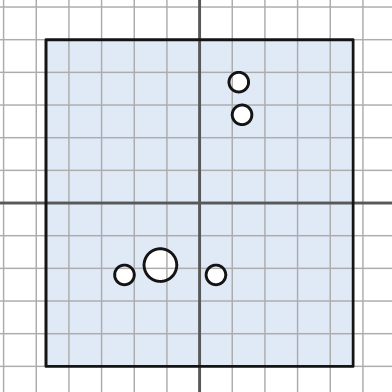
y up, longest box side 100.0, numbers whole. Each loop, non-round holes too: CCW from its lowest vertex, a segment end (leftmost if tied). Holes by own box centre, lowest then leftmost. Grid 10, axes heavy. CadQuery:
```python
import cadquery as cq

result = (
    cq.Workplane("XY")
    .moveTo(-47.0, -50.0)
    .lineTo(47.0, -50.0)
    .lineTo(47.0, 50.0)
    .lineTo(-47.0, 50.0)
    .close()
    .moveTo(-23.0, -22.0)
    .circle(3.0)
    .moveTo(5.0, -22.0)
    .circle(3.0)
    .moveTo(-12.0, -19.0)
    .circle(5.0)
    .moveTo(13.0, 27.0)
    .circle(3.0)
    .moveTo(12.0, 37.0)
    .circle(3.0)
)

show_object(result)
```